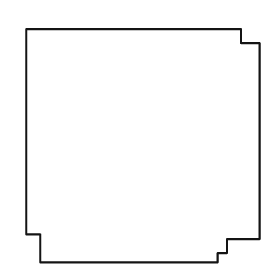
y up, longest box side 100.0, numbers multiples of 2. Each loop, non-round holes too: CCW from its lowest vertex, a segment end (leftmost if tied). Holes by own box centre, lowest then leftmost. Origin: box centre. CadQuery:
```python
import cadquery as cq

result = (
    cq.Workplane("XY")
    .moveTo(-44.0, -50.0)
    .lineTo(32.0, -50.0)
    .lineTo(32.0, -46.0)
    .lineTo(36.0, -46.0)
    .lineTo(36.0, -40.0)
    .lineTo(50.0, -40.0)
    .lineTo(50.0, 44.0)
    .lineTo(42.0, 44.0)
    .lineTo(42.0, 50.0)
    .lineTo(-50.0, 50.0)
    .lineTo(-50.0, -38.0)
    .lineTo(-44.0, -38.0)
    .close()
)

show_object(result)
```